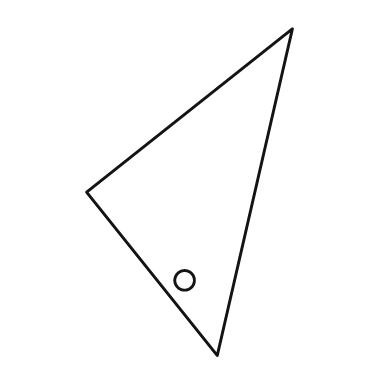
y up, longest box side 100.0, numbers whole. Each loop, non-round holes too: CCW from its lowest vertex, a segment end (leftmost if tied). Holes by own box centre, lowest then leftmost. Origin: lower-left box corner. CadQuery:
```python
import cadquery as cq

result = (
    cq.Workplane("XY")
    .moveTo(40.0, 0.0)
    .lineTo(63.0, 100.0)
    .lineTo(0.0, 50.0)
    .close()
    .moveTo(30.0, 23.0)
    .circle(3.0)
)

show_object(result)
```